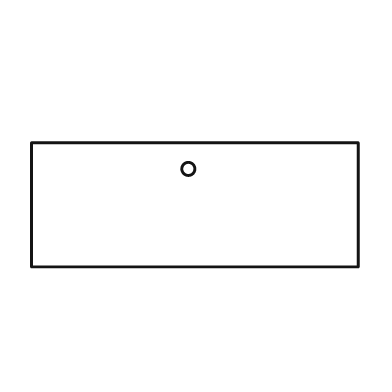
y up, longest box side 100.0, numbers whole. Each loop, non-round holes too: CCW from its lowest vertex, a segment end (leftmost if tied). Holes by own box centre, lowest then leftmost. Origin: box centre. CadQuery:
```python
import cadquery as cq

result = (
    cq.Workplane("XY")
    .moveTo(-50.0, -19.0)
    .lineTo(50.0, -19.0)
    .lineTo(50.0, 19.0)
    .lineTo(-50.0, 19.0)
    .close()
    .moveTo(-2.0, 11.0)
    .circle(2.0)
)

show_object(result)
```